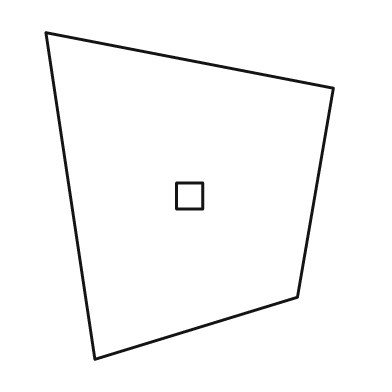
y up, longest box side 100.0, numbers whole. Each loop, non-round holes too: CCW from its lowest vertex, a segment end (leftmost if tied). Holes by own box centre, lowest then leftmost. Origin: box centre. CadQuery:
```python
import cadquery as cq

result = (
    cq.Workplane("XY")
    .moveTo(-29.0, -50.0)
    .lineTo(33.0, -31.0)
    .lineTo(44.0, 33.0)
    .lineTo(-44.0, 50.0)
    .close()
    .moveTo(-4.0, -4.0)
    .lineTo(4.0, -4.0)
    .lineTo(4.0, 4.0)
    .lineTo(-4.0, 4.0)
    .close()
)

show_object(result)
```